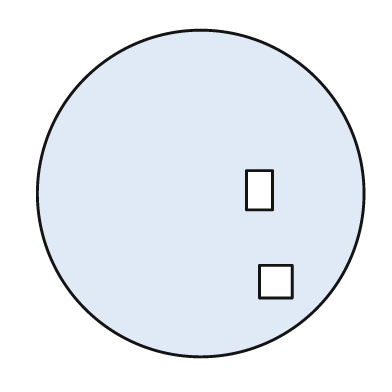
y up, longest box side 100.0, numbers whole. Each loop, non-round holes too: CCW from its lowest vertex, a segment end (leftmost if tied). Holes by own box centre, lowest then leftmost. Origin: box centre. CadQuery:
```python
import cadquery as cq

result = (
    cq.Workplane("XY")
    .moveTo(0.0, 0.0)
    .circle(50.0)
    .moveTo(18.0, -32.0)
    .lineTo(28.0, -32.0)
    .lineTo(28.0, -22.0)
    .lineTo(18.0, -22.0)
    .close()
    .moveTo(14.0, -5.0)
    .lineTo(22.0, -5.0)
    .lineTo(22.0, 7.0)
    .lineTo(14.0, 7.0)
    .close()
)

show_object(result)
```